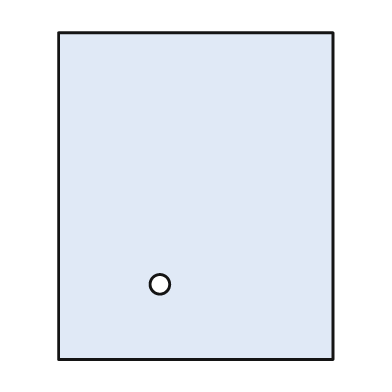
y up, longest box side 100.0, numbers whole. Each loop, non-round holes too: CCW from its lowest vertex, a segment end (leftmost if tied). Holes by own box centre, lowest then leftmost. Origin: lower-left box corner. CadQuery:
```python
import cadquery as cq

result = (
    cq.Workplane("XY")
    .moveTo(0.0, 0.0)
    .lineTo(84.0, 0.0)
    .lineTo(84.0, 100.0)
    .lineTo(0.0, 100.0)
    .close()
    .moveTo(31.0, 23.0)
    .circle(3.0)
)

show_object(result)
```